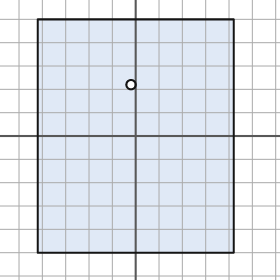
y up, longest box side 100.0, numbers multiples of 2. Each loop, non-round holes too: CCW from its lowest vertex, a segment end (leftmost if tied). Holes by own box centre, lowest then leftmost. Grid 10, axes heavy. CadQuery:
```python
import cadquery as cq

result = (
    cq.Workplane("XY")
    .moveTo(-42.0, -50.0)
    .lineTo(42.0, -50.0)
    .lineTo(42.0, 50.0)
    .lineTo(-42.0, 50.0)
    .close()
    .moveTo(-2.0, 22.0)
    .circle(2.0)
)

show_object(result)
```